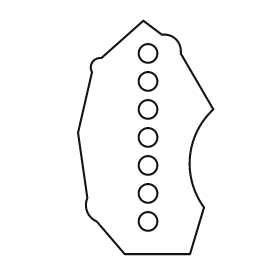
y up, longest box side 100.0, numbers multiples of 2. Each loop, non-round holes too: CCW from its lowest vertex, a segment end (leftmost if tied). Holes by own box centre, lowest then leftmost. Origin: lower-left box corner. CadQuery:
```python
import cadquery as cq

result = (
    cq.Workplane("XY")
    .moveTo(20.0, 0.0)
    .lineTo(48.0, 0.0)
    .lineTo(54.0, 20.0)
    .threePointArc((48.0, 42.0), (58.0, 62.0))
    .lineTo(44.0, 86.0)
    .threePointArc((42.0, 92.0), (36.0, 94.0))
    .lineTo(28.0, 100.0)
    .lineTo(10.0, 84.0)
    .threePointArc((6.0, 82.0), (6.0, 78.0))
    .lineTo(0.0, 52.0)
    .lineTo(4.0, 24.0)
    .threePointArc((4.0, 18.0), (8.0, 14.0))
    .close()
    .moveTo(30.0, 14.0)
    .circle(4.0)
    .moveTo(30.0, 26.0)
    .circle(4.0)
    .moveTo(30.0, 38.0)
    .circle(4.0)
    .moveTo(30.0, 50.0)
    .circle(4.0)
    .moveTo(30.0, 62.0)
    .circle(4.0)
    .moveTo(30.0, 74.0)
    .circle(4.0)
    .moveTo(30.0, 86.0)
    .circle(4.0)
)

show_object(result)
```